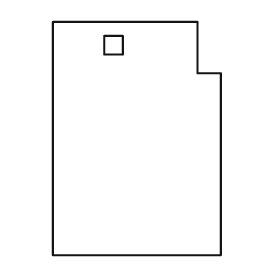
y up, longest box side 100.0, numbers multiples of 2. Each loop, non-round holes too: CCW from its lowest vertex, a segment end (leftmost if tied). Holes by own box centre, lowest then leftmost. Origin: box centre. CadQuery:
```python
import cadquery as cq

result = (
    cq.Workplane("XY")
    .moveTo(-36.0, -50.0)
    .lineTo(36.0, -50.0)
    .lineTo(36.0, 28.0)
    .lineTo(26.0, 28.0)
    .lineTo(26.0, 50.0)
    .lineTo(-36.0, 50.0)
    .close()
    .moveTo(-14.0, 36.0)
    .lineTo(-6.0, 36.0)
    .lineTo(-6.0, 44.0)
    .lineTo(-14.0, 44.0)
    .close()
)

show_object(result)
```